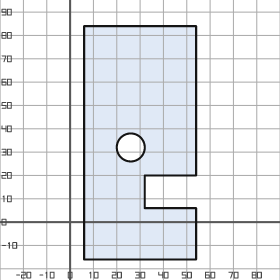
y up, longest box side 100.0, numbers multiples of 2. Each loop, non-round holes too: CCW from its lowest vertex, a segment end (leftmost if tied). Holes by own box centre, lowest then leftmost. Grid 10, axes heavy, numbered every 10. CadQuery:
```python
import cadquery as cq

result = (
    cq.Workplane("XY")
    .moveTo(6.0, -16.0)
    .lineTo(54.0, -16.0)
    .lineTo(54.0, 6.0)
    .lineTo(32.0, 6.0)
    .lineTo(32.0, 20.0)
    .lineTo(54.0, 20.0)
    .lineTo(54.0, 84.0)
    .lineTo(6.0, 84.0)
    .close()
    .moveTo(26.0, 32.0)
    .circle(6.0)
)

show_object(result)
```